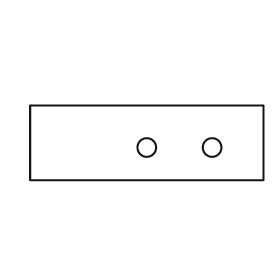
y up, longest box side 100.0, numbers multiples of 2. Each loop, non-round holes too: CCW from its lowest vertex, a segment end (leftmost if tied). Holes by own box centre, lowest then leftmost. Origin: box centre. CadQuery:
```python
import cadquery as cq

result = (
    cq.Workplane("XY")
    .moveTo(-50.0, -16.0)
    .lineTo(50.0, -16.0)
    .lineTo(50.0, 16.0)
    .lineTo(-50.0, 16.0)
    .close()
    .moveTo(0.0, -2.0)
    .circle(4.0)
    .moveTo(28.0, -2.0)
    .circle(4.0)
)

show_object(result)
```